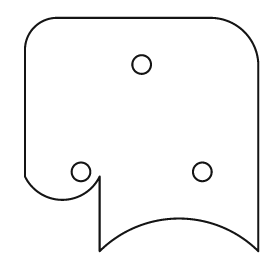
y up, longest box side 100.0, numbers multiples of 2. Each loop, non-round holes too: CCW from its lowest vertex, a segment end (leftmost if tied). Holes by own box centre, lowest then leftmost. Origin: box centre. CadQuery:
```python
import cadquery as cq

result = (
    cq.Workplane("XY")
    .moveTo(-18.0, -50.0)
    .threePointArc((16.0, -36.0), (50.0, -50.0))
    .lineTo(50.0, 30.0)
    .threePointArc((44.0, 44.0), (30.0, 50.0))
    .lineTo(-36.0, 50.0)
    .threePointArc((-46.0, 46.0), (-50.0, 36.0))
    .lineTo(-50.0, -18.0)
    .threePointArc((-34.0, -28.0), (-18.0, -18.0))
    .close()
    .moveTo(-26.0, -16.0)
    .circle(4.0)
    .moveTo(26.0, -16.0)
    .circle(4.0)
    .moveTo(0.0, 30.0)
    .circle(4.0)
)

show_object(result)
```